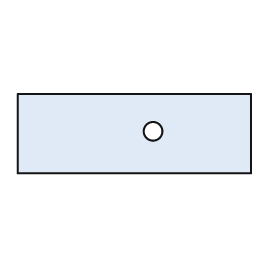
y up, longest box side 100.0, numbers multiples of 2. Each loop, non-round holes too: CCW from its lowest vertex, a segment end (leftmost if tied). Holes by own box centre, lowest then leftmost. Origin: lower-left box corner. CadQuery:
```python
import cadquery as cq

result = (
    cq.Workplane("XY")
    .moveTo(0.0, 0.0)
    .lineTo(100.0, 0.0)
    .lineTo(100.0, 34.0)
    .lineTo(0.0, 34.0)
    .close()
    .moveTo(58.0, 18.0)
    .circle(4.0)
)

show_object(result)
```